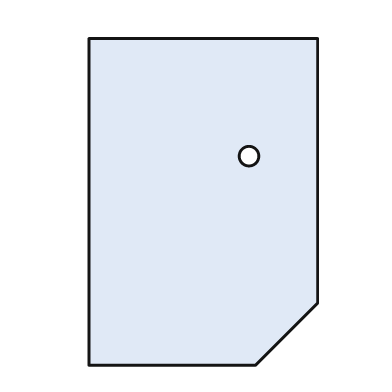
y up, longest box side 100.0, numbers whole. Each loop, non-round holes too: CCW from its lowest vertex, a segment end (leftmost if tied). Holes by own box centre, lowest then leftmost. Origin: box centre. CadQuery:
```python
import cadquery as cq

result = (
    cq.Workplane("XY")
    .moveTo(-35.0, -50.0)
    .lineTo(16.0, -50.0)
    .lineTo(35.0, -31.0)
    .lineTo(35.0, 50.0)
    .lineTo(-35.0, 50.0)
    .close()
    .moveTo(14.0, 14.0)
    .circle(3.0)
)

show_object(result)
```